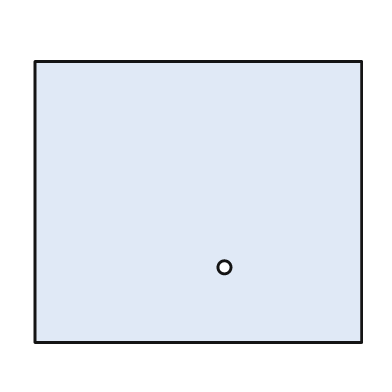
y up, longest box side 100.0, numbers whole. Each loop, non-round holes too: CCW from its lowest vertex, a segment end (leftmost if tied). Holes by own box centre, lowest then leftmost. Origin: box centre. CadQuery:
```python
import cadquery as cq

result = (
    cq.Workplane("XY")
    .moveTo(-50.0, -43.0)
    .lineTo(50.0, -43.0)
    .lineTo(50.0, 43.0)
    .lineTo(-50.0, 43.0)
    .close()
    .moveTo(8.0, -20.0)
    .circle(2.0)
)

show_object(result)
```